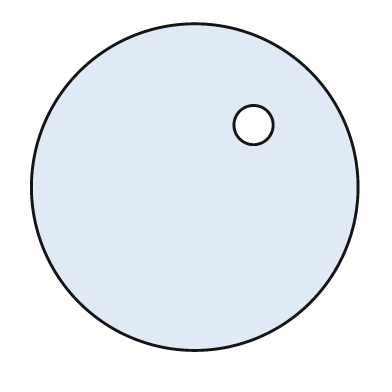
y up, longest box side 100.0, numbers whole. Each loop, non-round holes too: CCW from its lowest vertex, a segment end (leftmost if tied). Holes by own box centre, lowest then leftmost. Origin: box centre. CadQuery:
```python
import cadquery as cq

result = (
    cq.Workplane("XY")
    .moveTo(0.0, 0.0)
    .circle(50.0)
    .moveTo(18.0, 19.0)
    .circle(6.0)
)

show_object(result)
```